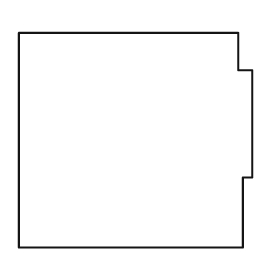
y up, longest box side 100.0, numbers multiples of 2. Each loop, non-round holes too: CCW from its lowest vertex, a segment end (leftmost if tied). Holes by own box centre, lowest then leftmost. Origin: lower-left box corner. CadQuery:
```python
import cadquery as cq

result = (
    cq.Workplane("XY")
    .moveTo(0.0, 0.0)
    .lineTo(96.0, 0.0)
    .lineTo(96.0, 30.0)
    .lineTo(100.0, 30.0)
    .lineTo(100.0, 76.0)
    .lineTo(94.0, 76.0)
    .lineTo(94.0, 92.0)
    .lineTo(0.0, 92.0)
    .close()
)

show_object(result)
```